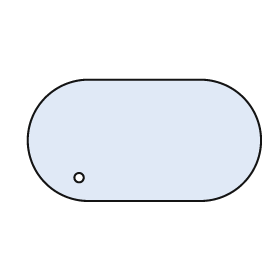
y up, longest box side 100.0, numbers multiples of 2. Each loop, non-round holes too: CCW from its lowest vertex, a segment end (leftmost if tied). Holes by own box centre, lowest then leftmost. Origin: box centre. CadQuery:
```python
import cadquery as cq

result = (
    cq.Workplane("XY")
    .moveTo(-24.0, -26.0)
    .lineTo(24.0, -26.0)
    .threePointArc((50.0, 0.0), (24.0, 26.0))
    .lineTo(-24.0, 26.0)
    .threePointArc((-50.0, 0.0), (-24.0, -26.0))
    .close()
    .moveTo(-28.0, -16.0)
    .circle(2.0)
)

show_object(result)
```